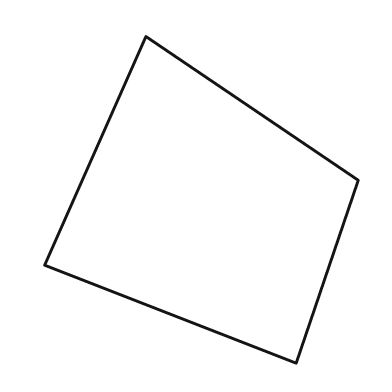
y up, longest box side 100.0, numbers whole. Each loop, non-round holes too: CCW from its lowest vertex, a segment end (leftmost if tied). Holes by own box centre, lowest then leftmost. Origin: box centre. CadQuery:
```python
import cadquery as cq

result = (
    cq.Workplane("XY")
    .moveTo(29.0, -50.0)
    .lineTo(48.0, 6.0)
    .lineTo(-17.0, 50.0)
    .lineTo(-48.0, -20.0)
    .close()
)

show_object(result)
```